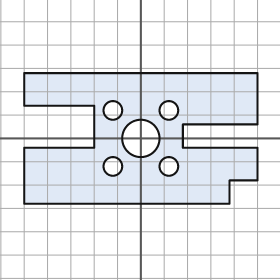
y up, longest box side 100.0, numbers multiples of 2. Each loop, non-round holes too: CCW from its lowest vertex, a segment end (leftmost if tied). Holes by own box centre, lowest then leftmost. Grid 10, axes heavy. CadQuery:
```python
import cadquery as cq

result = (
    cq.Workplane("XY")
    .moveTo(-50.0, -28.0)
    .lineTo(38.0, -28.0)
    .lineTo(38.0, -18.0)
    .lineTo(50.0, -18.0)
    .lineTo(50.0, -4.0)
    .lineTo(18.0, -4.0)
    .lineTo(18.0, 6.0)
    .lineTo(50.0, 6.0)
    .lineTo(50.0, 28.0)
    .lineTo(-50.0, 28.0)
    .lineTo(-50.0, 14.0)
    .lineTo(-20.0, 14.0)
    .lineTo(-20.0, -4.0)
    .lineTo(-50.0, -4.0)
    .close()
    .moveTo(-12.0, -12.0)
    .circle(4.0)
    .moveTo(12.0, -12.0)
    .circle(4.0)
    .moveTo(0.0, 0.0)
    .circle(8.0)
    .moveTo(-12.0, 12.0)
    .circle(4.0)
    .moveTo(12.0, 12.0)
    .circle(4.0)
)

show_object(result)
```